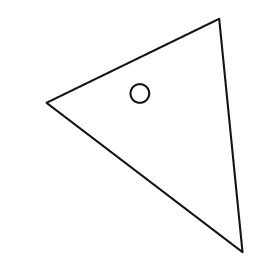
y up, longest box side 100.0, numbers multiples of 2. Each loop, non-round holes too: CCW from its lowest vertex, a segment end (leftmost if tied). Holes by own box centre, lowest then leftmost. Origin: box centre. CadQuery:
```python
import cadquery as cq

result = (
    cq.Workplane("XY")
    .moveTo(42.0, -50.0)
    .lineTo(32.0, 50.0)
    .lineTo(-42.0, 14.0)
    .close()
    .moveTo(-2.0, 18.0)
    .circle(4.0)
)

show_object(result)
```